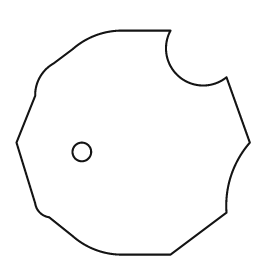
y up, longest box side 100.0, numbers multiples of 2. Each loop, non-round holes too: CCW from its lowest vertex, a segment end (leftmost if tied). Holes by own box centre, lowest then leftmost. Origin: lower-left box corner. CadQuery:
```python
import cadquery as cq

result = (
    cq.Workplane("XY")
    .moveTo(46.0, 0.0)
    .lineTo(66.0, 0.0)
    .lineTo(90.0, 18.0)
    .threePointArc((92.0, 34.0), (100.0, 48.0))
    .lineTo(90.0, 76.0)
    .threePointArc((70.0, 76.0), (66.0, 96.0))
    .lineTo(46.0, 96.0)
    .threePointArc((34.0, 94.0), (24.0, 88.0))
    .lineTo(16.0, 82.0)
    .threePointArc((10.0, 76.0), (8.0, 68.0))
    .lineTo(0.0, 48.0)
    .lineTo(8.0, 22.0)
    .threePointArc((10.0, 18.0), (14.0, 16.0))
    .lineTo(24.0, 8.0)
    .threePointArc((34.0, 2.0), (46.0, 0.0))
    .close()
    .moveTo(28.0, 44.0)
    .circle(4.0)
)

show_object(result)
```